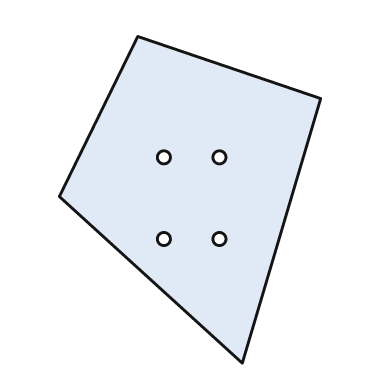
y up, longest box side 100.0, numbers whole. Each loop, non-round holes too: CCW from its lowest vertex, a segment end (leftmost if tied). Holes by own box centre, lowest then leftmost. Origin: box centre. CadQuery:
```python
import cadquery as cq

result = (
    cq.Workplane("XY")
    .moveTo(16.0, -50.0)
    .lineTo(40.0, 31.0)
    .lineTo(-16.0, 50.0)
    .lineTo(-40.0, 1.0)
    .close()
    .moveTo(-8.0, -12.0)
    .circle(2.0)
    .moveTo(9.0, -12.0)
    .circle(2.0)
    .moveTo(-8.0, 13.0)
    .circle(2.0)
    .moveTo(9.0, 13.0)
    .circle(2.0)
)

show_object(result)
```